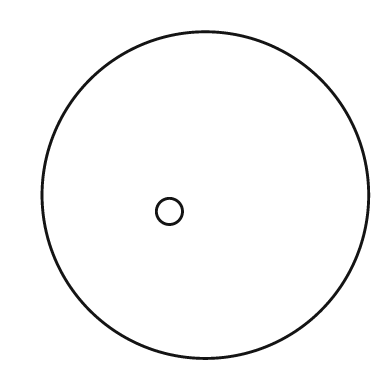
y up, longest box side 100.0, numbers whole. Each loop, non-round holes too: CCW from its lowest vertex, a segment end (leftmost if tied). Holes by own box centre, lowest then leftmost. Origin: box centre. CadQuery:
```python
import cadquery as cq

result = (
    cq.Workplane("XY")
    .moveTo(0.0, 0.0)
    .circle(50.0)
    .moveTo(-11.0, -5.0)
    .circle(4.0)
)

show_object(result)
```